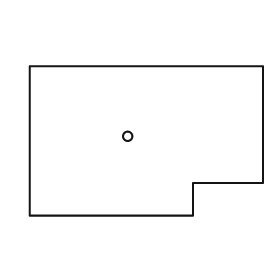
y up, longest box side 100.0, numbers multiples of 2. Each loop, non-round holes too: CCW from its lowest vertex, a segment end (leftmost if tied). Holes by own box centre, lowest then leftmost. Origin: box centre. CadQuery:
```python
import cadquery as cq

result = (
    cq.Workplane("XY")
    .moveTo(-50.0, -32.0)
    .lineTo(20.0, -32.0)
    .lineTo(20.0, -18.0)
    .lineTo(50.0, -18.0)
    .lineTo(50.0, 32.0)
    .lineTo(-50.0, 32.0)
    .close()
    .moveTo(-8.0, 2.0)
    .circle(2.0)
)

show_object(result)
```